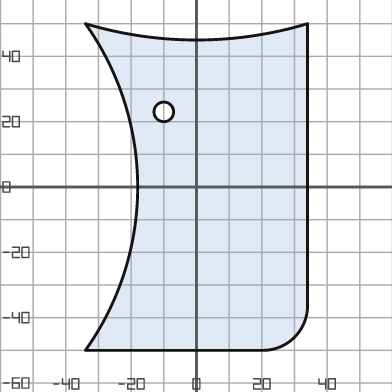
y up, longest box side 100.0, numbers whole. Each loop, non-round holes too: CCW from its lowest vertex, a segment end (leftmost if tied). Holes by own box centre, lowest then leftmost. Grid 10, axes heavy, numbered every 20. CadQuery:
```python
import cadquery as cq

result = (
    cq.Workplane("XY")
    .moveTo(-34.0, -50.0)
    .lineTo(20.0, -50.0)
    .threePointArc((30.0, -46.0), (34.0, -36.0))
    .lineTo(34.0, 50.0)
    .threePointArc((0.0, 45.0), (-34.0, 50.0))
    .threePointArc((-18.0, 0.0), (-34.0, -50.0))
    .close()
    .moveTo(-10.0, 23.0)
    .circle(3.0)
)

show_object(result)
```